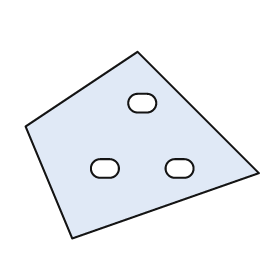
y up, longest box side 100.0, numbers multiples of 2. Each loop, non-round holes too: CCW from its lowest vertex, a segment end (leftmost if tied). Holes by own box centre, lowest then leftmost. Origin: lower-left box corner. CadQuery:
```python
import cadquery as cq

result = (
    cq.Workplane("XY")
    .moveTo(20.0, 0.0)
    .lineTo(100.0, 28.0)
    .lineTo(48.0, 80.0)
    .lineTo(0.0, 48.0)
    .close()
    .moveTo(32.0, 26.0)
    .lineTo(36.0, 26.0)
    .threePointArc((40.0, 30.0), (36.0, 34.0))
    .lineTo(32.0, 34.0)
    .threePointArc((28.0, 30.0), (32.0, 26.0))
    .close()
    .moveTo(64.0, 26.0)
    .lineTo(68.0, 26.0)
    .threePointArc((72.0, 30.0), (68.0, 34.0))
    .lineTo(64.0, 34.0)
    .threePointArc((60.0, 30.0), (64.0, 26.0))
    .close()
    .moveTo(48.0, 54.0)
    .lineTo(52.0, 54.0)
    .threePointArc((56.0, 58.0), (52.0, 62.0))
    .lineTo(48.0, 62.0)
    .threePointArc((44.0, 58.0), (48.0, 54.0))
    .close()
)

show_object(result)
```